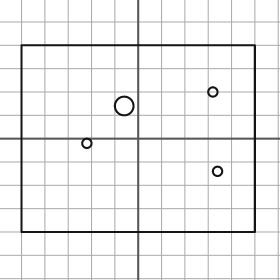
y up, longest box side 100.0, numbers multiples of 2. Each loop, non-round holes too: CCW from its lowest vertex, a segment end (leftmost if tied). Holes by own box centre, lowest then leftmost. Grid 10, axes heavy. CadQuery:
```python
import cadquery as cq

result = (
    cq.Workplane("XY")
    .moveTo(-50.0, -40.0)
    .lineTo(50.0, -40.0)
    .lineTo(50.0, 40.0)
    .lineTo(-50.0, 40.0)
    .close()
    .moveTo(34.0, -14.0)
    .circle(2.0)
    .moveTo(-22.0, -2.0)
    .circle(2.0)
    .moveTo(-6.0, 14.0)
    .circle(4.0)
    .moveTo(32.0, 20.0)
    .circle(2.0)
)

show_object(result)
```